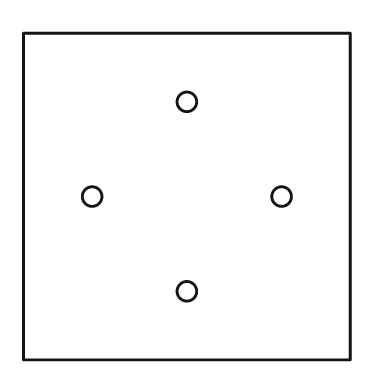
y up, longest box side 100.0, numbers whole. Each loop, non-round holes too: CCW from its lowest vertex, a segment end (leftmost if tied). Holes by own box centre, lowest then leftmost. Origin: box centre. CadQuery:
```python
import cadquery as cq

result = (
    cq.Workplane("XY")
    .moveTo(-50.0, -50.0)
    .lineTo(50.0, -50.0)
    .lineTo(50.0, 50.0)
    .lineTo(-50.0, 50.0)
    .close()
    .moveTo(0.0, -29.0)
    .circle(3.0)
    .moveTo(-29.0, 0.0)
    .circle(3.0)
    .moveTo(29.0, 0.0)
    .circle(3.0)
    .moveTo(0.0, 29.0)
    .circle(3.0)
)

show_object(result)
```